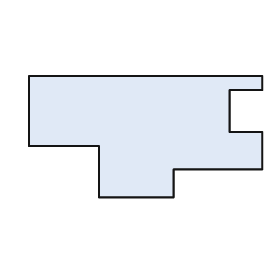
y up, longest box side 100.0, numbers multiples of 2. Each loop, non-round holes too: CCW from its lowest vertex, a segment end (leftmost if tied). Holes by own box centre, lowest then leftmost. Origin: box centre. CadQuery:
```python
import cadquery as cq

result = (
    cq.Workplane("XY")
    .moveTo(-20.0, -26.0)
    .lineTo(12.0, -26.0)
    .lineTo(12.0, -14.0)
    .lineTo(50.0, -14.0)
    .lineTo(50.0, 2.0)
    .lineTo(36.0, 2.0)
    .lineTo(36.0, 20.0)
    .lineTo(50.0, 20.0)
    .lineTo(50.0, 26.0)
    .lineTo(-50.0, 26.0)
    .lineTo(-50.0, -4.0)
    .lineTo(-20.0, -4.0)
    .close()
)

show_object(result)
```